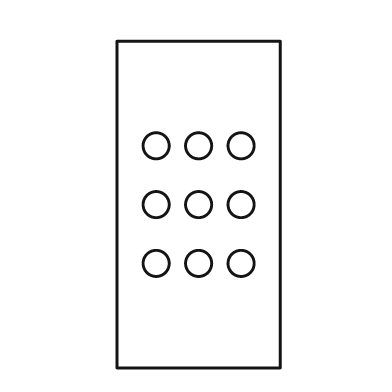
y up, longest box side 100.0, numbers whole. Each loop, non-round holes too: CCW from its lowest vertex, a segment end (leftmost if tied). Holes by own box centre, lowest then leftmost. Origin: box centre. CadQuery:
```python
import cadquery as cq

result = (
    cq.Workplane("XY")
    .moveTo(-25.0, -50.0)
    .lineTo(25.0, -50.0)
    .lineTo(25.0, 50.0)
    .lineTo(-25.0, 50.0)
    .close()
    .moveTo(-13.0, -18.0)
    .circle(4.0)
    .moveTo(0.0, -18.0)
    .circle(4.0)
    .moveTo(13.0, -18.0)
    .circle(4.0)
    .moveTo(-13.0, 0.0)
    .circle(4.0)
    .moveTo(0.0, 0.0)
    .circle(4.0)
    .moveTo(13.0, 0.0)
    .circle(4.0)
    .moveTo(-13.0, 18.0)
    .circle(4.0)
    .moveTo(0.0, 18.0)
    .circle(4.0)
    .moveTo(13.0, 18.0)
    .circle(4.0)
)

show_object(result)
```